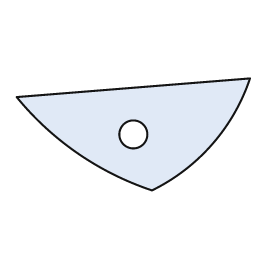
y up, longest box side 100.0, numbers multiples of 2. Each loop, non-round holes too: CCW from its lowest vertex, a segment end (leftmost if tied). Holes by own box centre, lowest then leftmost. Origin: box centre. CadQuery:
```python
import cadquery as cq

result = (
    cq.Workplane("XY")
    .moveTo(8.0, -24.0)
    .threePointArc((34.0, -4.0), (50.0, 24.0))
    .lineTo(-50.0, 16.0)
    .threePointArc((-24.0, -8.0), (8.0, -24.0))
    .close()
    .moveTo(0.0, 0.0)
    .circle(6.0)
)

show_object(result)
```